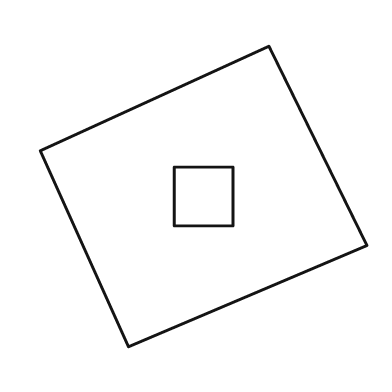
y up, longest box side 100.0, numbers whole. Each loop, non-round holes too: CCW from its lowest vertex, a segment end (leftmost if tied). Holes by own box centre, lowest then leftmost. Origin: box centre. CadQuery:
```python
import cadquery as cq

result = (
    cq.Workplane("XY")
    .moveTo(-23.0, -46.0)
    .lineTo(50.0, -15.0)
    .lineTo(20.0, 46.0)
    .lineTo(-50.0, 14.0)
    .close()
    .moveTo(-9.0, -9.0)
    .lineTo(9.0, -9.0)
    .lineTo(9.0, 9.0)
    .lineTo(-9.0, 9.0)
    .close()
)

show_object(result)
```